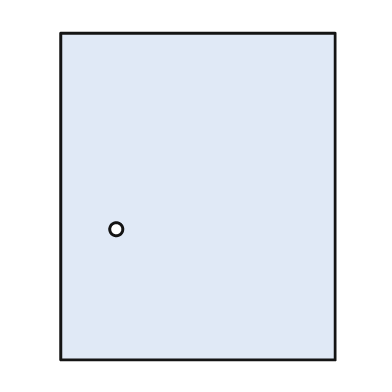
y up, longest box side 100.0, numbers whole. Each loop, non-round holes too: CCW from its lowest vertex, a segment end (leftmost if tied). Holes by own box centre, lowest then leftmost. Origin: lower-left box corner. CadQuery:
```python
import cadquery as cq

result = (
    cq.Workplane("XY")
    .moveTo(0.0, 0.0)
    .lineTo(84.0, 0.0)
    .lineTo(84.0, 100.0)
    .lineTo(0.0, 100.0)
    .close()
    .moveTo(17.0, 40.0)
    .circle(2.0)
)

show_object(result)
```